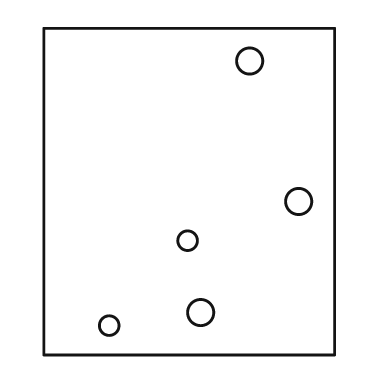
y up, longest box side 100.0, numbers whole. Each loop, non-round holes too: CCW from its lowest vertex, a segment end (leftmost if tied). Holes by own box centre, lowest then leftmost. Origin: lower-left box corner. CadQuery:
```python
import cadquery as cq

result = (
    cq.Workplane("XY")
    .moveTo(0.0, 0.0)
    .lineTo(89.0, 0.0)
    .lineTo(89.0, 100.0)
    .lineTo(0.0, 100.0)
    .close()
    .moveTo(20.0, 9.0)
    .circle(3.0)
    .moveTo(48.0, 13.0)
    .circle(4.0)
    .moveTo(44.0, 35.0)
    .circle(3.0)
    .moveTo(78.0, 47.0)
    .circle(4.0)
    .moveTo(63.0, 90.0)
    .circle(4.0)
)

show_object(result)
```